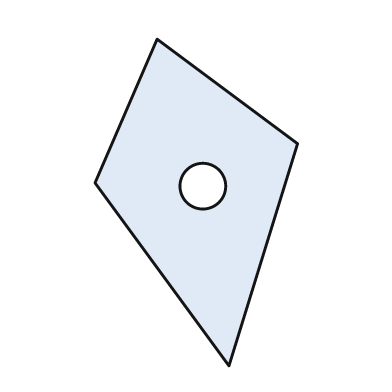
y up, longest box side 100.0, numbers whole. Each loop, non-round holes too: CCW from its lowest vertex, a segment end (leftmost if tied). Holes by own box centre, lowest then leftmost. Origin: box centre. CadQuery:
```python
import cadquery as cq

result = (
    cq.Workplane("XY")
    .moveTo(10.0, -50.0)
    .lineTo(31.0, 18.0)
    .lineTo(-12.0, 50.0)
    .lineTo(-31.0, 6.0)
    .close()
    .moveTo(2.0, 5.0)
    .circle(7.0)
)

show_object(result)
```